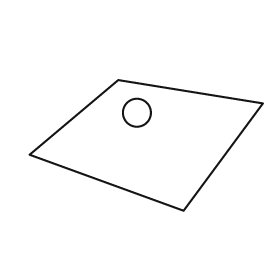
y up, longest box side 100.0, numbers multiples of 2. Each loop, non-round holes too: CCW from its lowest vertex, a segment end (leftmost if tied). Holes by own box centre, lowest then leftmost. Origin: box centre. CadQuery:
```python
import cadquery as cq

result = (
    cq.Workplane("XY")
    .moveTo(16.0, -28.0)
    .lineTo(50.0, 18.0)
    .lineTo(-12.0, 28.0)
    .lineTo(-50.0, -4.0)
    .close()
    .moveTo(-4.0, 14.0)
    .circle(6.0)
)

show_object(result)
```